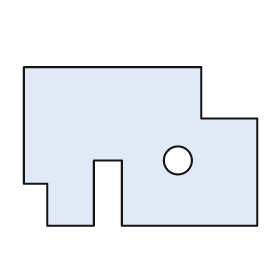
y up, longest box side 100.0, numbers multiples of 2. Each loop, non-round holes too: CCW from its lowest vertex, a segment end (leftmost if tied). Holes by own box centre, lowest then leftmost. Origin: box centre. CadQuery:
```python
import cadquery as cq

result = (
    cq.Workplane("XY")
    .moveTo(-40.0, -34.0)
    .lineTo(-20.0, -34.0)
    .lineTo(-20.0, -6.0)
    .lineTo(-8.0, -6.0)
    .lineTo(-8.0, -34.0)
    .lineTo(50.0, -34.0)
    .lineTo(50.0, 12.0)
    .lineTo(26.0, 12.0)
    .lineTo(26.0, 34.0)
    .lineTo(-50.0, 34.0)
    .lineTo(-50.0, -16.0)
    .lineTo(-40.0, -16.0)
    .close()
    .moveTo(16.0, -6.0)
    .circle(6.0)
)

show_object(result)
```